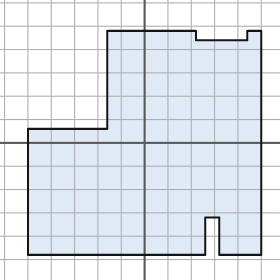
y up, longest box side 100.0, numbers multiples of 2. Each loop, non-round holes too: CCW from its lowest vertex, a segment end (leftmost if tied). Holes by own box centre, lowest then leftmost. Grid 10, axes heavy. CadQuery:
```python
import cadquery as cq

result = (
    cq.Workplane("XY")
    .moveTo(-50.0, -48.0)
    .lineTo(26.0, -48.0)
    .lineTo(26.0, -32.0)
    .lineTo(32.0, -32.0)
    .lineTo(32.0, -48.0)
    .lineTo(50.0, -48.0)
    .lineTo(50.0, 48.0)
    .lineTo(44.0, 48.0)
    .lineTo(44.0, 44.0)
    .lineTo(22.0, 44.0)
    .lineTo(22.0, 48.0)
    .lineTo(-16.0, 48.0)
    .lineTo(-16.0, 6.0)
    .lineTo(-50.0, 6.0)
    .close()
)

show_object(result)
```